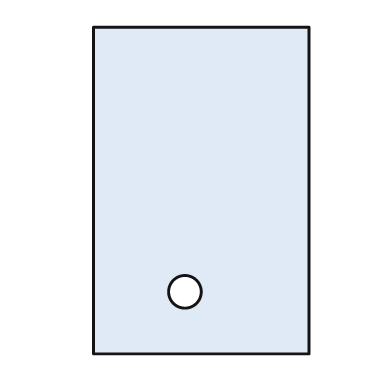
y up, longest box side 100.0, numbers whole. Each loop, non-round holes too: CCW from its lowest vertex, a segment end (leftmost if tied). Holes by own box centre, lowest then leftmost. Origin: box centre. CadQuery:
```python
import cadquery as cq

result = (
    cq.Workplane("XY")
    .moveTo(-33.0, -50.0)
    .lineTo(33.0, -50.0)
    .lineTo(33.0, 50.0)
    .lineTo(-33.0, 50.0)
    .close()
    .moveTo(-5.0, -31.0)
    .circle(5.0)
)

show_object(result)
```